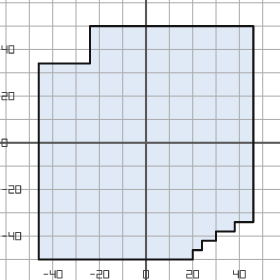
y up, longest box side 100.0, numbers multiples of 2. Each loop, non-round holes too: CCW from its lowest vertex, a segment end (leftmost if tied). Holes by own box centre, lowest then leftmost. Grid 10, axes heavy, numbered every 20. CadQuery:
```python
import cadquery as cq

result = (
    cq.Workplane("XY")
    .moveTo(-46.0, -50.0)
    .lineTo(20.0, -50.0)
    .lineTo(20.0, -46.0)
    .lineTo(24.0, -46.0)
    .lineTo(24.0, -42.0)
    .lineTo(30.0, -42.0)
    .lineTo(30.0, -38.0)
    .lineTo(38.0, -38.0)
    .lineTo(38.0, -34.0)
    .lineTo(46.0, -34.0)
    .lineTo(46.0, 50.0)
    .lineTo(-24.0, 50.0)
    .lineTo(-24.0, 34.0)
    .lineTo(-46.0, 34.0)
    .close()
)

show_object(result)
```